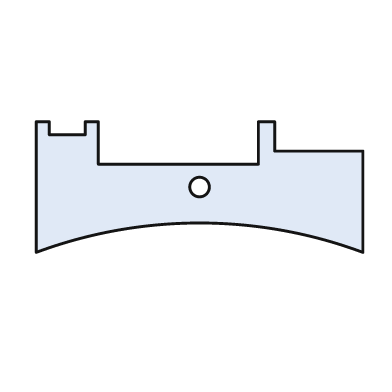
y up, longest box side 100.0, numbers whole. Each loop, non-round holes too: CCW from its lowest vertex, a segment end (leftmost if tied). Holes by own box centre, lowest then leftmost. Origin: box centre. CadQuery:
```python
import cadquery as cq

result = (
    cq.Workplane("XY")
    .moveTo(-50.0, -20.0)
    .threePointArc((0.0, -11.0), (50.0, -20.0))
    .lineTo(50.0, 11.0)
    .lineTo(23.0, 11.0)
    .lineTo(23.0, 20.0)
    .lineTo(18.0, 20.0)
    .lineTo(18.0, 7.0)
    .lineTo(-31.0, 7.0)
    .lineTo(-31.0, 20.0)
    .lineTo(-35.0, 20.0)
    .lineTo(-35.0, 16.0)
    .lineTo(-46.0, 16.0)
    .lineTo(-46.0, 20.0)
    .lineTo(-50.0, 20.0)
    .close()
    .moveTo(0.0, 0.0)
    .circle(3.0)
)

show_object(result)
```